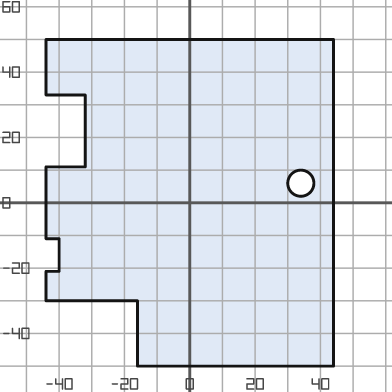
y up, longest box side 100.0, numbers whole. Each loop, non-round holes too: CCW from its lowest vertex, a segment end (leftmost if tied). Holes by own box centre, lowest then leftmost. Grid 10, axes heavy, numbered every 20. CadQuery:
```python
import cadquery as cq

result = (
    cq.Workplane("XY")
    .moveTo(-16.0, -50.0)
    .lineTo(44.0, -50.0)
    .lineTo(44.0, 50.0)
    .lineTo(-44.0, 50.0)
    .lineTo(-44.0, 33.0)
    .lineTo(-32.0, 33.0)
    .lineTo(-32.0, 11.0)
    .lineTo(-44.0, 11.0)
    .lineTo(-44.0, -11.0)
    .lineTo(-40.0, -11.0)
    .lineTo(-40.0, -21.0)
    .lineTo(-44.0, -21.0)
    .lineTo(-44.0, -30.0)
    .lineTo(-16.0, -30.0)
    .close()
    .moveTo(34.0, 6.0)
    .circle(4.0)
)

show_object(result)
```